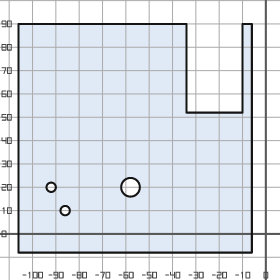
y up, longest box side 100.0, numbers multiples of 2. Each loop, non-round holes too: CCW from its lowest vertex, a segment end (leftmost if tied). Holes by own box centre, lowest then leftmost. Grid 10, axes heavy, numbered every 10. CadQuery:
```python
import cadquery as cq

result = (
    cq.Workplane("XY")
    .moveTo(-106.0, -8.0)
    .lineTo(-6.0, -8.0)
    .lineTo(-6.0, 90.0)
    .lineTo(-10.0, 90.0)
    .lineTo(-10.0, 52.0)
    .lineTo(-34.0, 52.0)
    .lineTo(-34.0, 90.0)
    .lineTo(-106.0, 90.0)
    .close()
    .moveTo(-86.0, 10.0)
    .circle(2.0)
    .moveTo(-92.0, 20.0)
    .circle(2.0)
    .moveTo(-58.0, 20.0)
    .circle(4.0)
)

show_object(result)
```